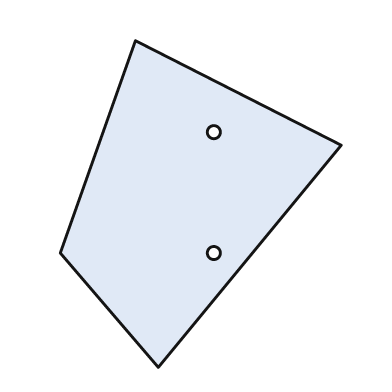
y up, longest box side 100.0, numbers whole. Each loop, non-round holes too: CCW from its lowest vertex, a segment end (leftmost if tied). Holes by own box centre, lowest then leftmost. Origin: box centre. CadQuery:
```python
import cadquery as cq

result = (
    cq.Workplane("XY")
    .moveTo(-13.0, -50.0)
    .lineTo(43.0, 18.0)
    .lineTo(-20.0, 50.0)
    .lineTo(-43.0, -15.0)
    .close()
    .moveTo(4.0, -15.0)
    .circle(2.0)
    .moveTo(4.0, 22.0)
    .circle(2.0)
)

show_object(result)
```